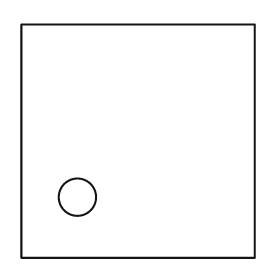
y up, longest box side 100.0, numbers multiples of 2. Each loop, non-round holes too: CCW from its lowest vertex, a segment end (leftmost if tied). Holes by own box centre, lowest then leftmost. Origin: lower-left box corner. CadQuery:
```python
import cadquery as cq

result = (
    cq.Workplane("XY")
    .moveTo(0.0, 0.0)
    .lineTo(100.0, 0.0)
    .lineTo(100.0, 100.0)
    .lineTo(0.0, 100.0)
    .close()
    .moveTo(24.0, 26.0)
    .circle(8.0)
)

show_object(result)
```